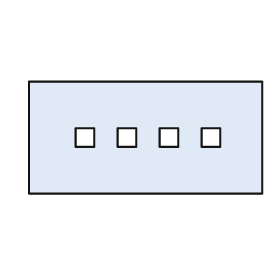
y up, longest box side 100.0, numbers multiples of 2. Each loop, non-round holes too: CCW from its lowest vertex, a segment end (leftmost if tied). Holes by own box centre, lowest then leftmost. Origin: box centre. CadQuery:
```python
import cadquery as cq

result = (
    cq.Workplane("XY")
    .moveTo(-50.0, -24.0)
    .lineTo(50.0, -24.0)
    .lineTo(50.0, 24.0)
    .lineTo(-50.0, 24.0)
    .close()
    .moveTo(-30.0, -4.0)
    .lineTo(-22.0, -4.0)
    .lineTo(-22.0, 4.0)
    .lineTo(-30.0, 4.0)
    .close()
    .moveTo(-12.0, -4.0)
    .lineTo(-4.0, -4.0)
    .lineTo(-4.0, 4.0)
    .lineTo(-12.0, 4.0)
    .close()
    .moveTo(6.0, -4.0)
    .lineTo(14.0, -4.0)
    .lineTo(14.0, 4.0)
    .lineTo(6.0, 4.0)
    .close()
    .moveTo(24.0, -4.0)
    .lineTo(32.0, -4.0)
    .lineTo(32.0, 4.0)
    .lineTo(24.0, 4.0)
    .close()
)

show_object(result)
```